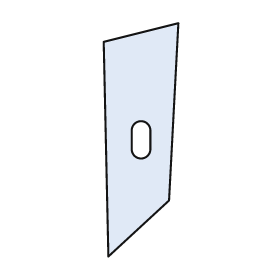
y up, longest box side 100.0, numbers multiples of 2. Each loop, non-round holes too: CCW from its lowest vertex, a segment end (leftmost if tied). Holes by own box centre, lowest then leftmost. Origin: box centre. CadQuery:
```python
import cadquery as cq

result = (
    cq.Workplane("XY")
    .moveTo(-14.0, -50.0)
    .lineTo(12.0, -26.0)
    .lineTo(16.0, 50.0)
    .lineTo(-16.0, 42.0)
    .close()
    .moveTo(-4.0, -4.0)
    .threePointArc((0.0, -8.0), (4.0, -4.0))
    .lineTo(4.0, 4.0)
    .threePointArc((0.0, 8.0), (-4.0, 4.0))
    .close()
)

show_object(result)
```